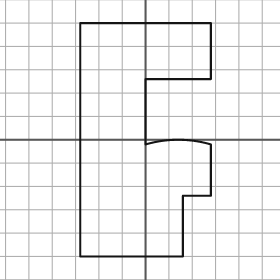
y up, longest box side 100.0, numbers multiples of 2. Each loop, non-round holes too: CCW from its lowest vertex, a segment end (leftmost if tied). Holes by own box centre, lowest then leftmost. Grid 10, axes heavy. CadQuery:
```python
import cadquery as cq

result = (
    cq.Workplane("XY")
    .moveTo(-28.0, -50.0)
    .lineTo(16.0, -50.0)
    .lineTo(16.0, -24.0)
    .lineTo(28.0, -24.0)
    .lineTo(28.0, -2.0)
    .threePointArc((14.0, 0.0), (0.0, -2.0))
    .lineTo(0.0, 26.0)
    .lineTo(28.0, 26.0)
    .lineTo(28.0, 50.0)
    .lineTo(-28.0, 50.0)
    .close()
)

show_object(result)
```